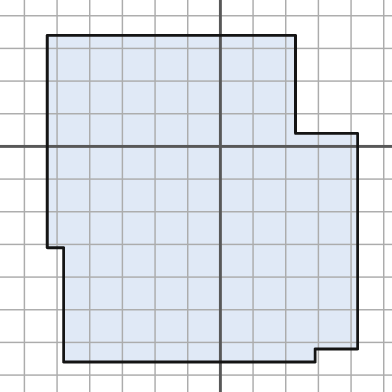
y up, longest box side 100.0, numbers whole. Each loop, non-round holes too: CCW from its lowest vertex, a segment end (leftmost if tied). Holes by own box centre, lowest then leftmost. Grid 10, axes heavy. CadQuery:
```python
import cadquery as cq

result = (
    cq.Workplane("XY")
    .moveTo(-48.0, -66.0)
    .lineTo(29.0, -66.0)
    .lineTo(29.0, -62.0)
    .lineTo(42.0, -62.0)
    .lineTo(42.0, 4.0)
    .lineTo(23.0, 4.0)
    .lineTo(23.0, 34.0)
    .lineTo(-53.0, 34.0)
    .lineTo(-53.0, -31.0)
    .lineTo(-48.0, -31.0)
    .close()
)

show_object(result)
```